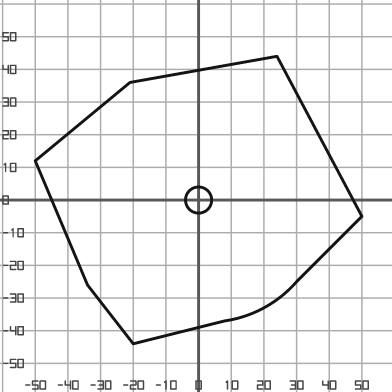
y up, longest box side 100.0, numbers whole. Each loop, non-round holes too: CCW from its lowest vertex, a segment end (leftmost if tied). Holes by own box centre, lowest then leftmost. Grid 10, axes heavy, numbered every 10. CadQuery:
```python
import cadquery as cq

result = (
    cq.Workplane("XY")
    .moveTo(-20.0, -44.0)
    .lineTo(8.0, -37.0)
    .threePointArc((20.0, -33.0), (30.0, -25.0))
    .lineTo(50.0, -5.0)
    .lineTo(24.0, 44.0)
    .lineTo(-21.0, 36.0)
    .lineTo(-50.0, 12.0)
    .lineTo(-34.0, -26.0)
    .close()
    .moveTo(0.0, 0.0)
    .circle(4.0)
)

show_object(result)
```